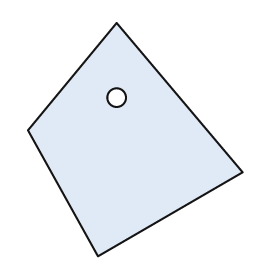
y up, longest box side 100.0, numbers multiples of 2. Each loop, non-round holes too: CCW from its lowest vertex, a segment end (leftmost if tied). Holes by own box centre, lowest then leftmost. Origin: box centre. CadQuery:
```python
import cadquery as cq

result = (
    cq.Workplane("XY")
    .moveTo(-16.0, -50.0)
    .lineTo(46.0, -14.0)
    .lineTo(-8.0, 50.0)
    .lineTo(-46.0, 4.0)
    .close()
    .moveTo(-8.0, 18.0)
    .circle(4.0)
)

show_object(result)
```